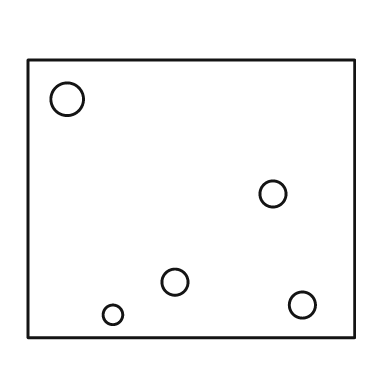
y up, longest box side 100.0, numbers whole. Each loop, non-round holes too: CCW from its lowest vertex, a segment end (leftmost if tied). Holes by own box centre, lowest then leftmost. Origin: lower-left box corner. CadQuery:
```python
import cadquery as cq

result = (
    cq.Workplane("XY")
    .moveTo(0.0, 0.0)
    .lineTo(100.0, 0.0)
    .lineTo(100.0, 85.0)
    .lineTo(0.0, 85.0)
    .close()
    .moveTo(26.0, 7.0)
    .circle(3.0)
    .moveTo(84.0, 10.0)
    .circle(4.0)
    .moveTo(45.0, 17.0)
    .circle(4.0)
    .moveTo(75.0, 44.0)
    .circle(4.0)
    .moveTo(12.0, 73.0)
    .circle(5.0)
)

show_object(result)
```